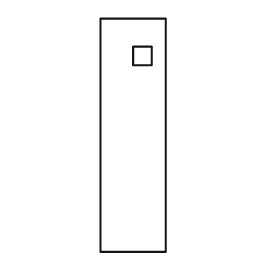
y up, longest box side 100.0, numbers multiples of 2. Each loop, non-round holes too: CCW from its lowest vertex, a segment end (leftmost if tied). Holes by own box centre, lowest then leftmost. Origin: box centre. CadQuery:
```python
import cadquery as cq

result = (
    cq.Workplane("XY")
    .moveTo(-14.0, -50.0)
    .lineTo(14.0, -50.0)
    .lineTo(14.0, 50.0)
    .lineTo(-14.0, 50.0)
    .close()
    .moveTo(0.0, 30.0)
    .lineTo(8.0, 30.0)
    .lineTo(8.0, 38.0)
    .lineTo(0.0, 38.0)
    .close()
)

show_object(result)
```